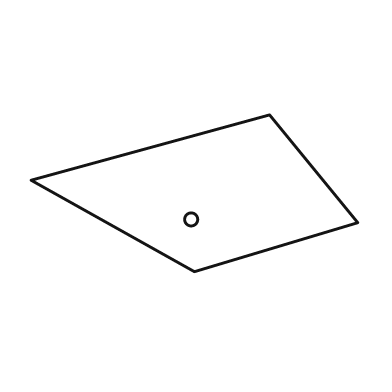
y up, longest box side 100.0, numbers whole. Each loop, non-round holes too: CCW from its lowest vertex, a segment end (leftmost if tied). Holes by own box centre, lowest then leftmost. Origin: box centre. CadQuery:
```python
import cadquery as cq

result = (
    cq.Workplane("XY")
    .moveTo(0.0, -24.0)
    .lineTo(50.0, -9.0)
    .lineTo(23.0, 24.0)
    .lineTo(-50.0, 4.0)
    .close()
    .moveTo(-1.0, -8.0)
    .circle(2.0)
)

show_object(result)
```